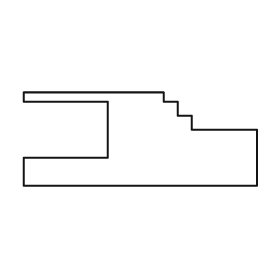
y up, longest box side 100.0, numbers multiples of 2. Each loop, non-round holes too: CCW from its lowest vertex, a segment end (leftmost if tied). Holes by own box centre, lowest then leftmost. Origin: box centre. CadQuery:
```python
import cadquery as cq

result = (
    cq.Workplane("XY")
    .moveTo(-50.0, -20.0)
    .lineTo(50.0, -20.0)
    .lineTo(50.0, 4.0)
    .lineTo(22.0, 4.0)
    .lineTo(22.0, 10.0)
    .lineTo(16.0, 10.0)
    .lineTo(16.0, 16.0)
    .lineTo(10.0, 16.0)
    .lineTo(10.0, 20.0)
    .lineTo(-50.0, 20.0)
    .lineTo(-50.0, 16.0)
    .lineTo(-14.0, 16.0)
    .lineTo(-14.0, -8.0)
    .lineTo(-50.0, -8.0)
    .close()
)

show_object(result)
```